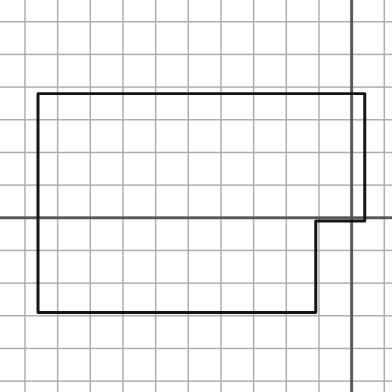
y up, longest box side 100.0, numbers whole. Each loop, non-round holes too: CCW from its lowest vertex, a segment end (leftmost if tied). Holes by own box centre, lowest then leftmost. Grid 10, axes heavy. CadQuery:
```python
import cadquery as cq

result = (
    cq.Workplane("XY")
    .moveTo(-96.0, -29.0)
    .lineTo(-11.0, -29.0)
    .lineTo(-11.0, -1.0)
    .lineTo(4.0, -1.0)
    .lineTo(4.0, 38.0)
    .lineTo(-96.0, 38.0)
    .close()
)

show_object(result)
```